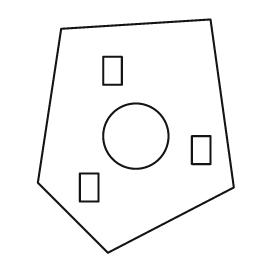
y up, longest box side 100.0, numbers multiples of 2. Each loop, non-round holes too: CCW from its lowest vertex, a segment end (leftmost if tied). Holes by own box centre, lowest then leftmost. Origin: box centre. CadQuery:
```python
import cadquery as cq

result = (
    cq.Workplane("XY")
    .moveTo(-12.0, -50.0)
    .lineTo(42.0, -22.0)
    .lineTo(32.0, 50.0)
    .lineTo(-32.0, 46.0)
    .lineTo(-42.0, -20.0)
    .close()
    .moveTo(-24.0, -28.0)
    .lineTo(-16.0, -28.0)
    .lineTo(-16.0, -16.0)
    .lineTo(-24.0, -16.0)
    .close()
    .moveTo(24.0, -12.0)
    .lineTo(32.0, -12.0)
    .lineTo(32.0, 0.0)
    .lineTo(24.0, 0.0)
    .close()
    .moveTo(0.0, 0.0)
    .circle(14.0)
    .moveTo(-14.0, 22.0)
    .lineTo(-6.0, 22.0)
    .lineTo(-6.0, 34.0)
    .lineTo(-14.0, 34.0)
    .close()
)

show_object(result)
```